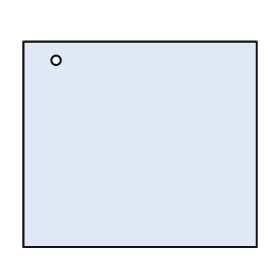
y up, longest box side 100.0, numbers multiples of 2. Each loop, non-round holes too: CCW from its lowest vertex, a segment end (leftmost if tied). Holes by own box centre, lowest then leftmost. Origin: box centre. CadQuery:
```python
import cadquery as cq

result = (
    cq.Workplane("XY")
    .moveTo(-50.0, -44.0)
    .lineTo(50.0, -44.0)
    .lineTo(50.0, 44.0)
    .lineTo(-50.0, 44.0)
    .close()
    .moveTo(-36.0, 36.0)
    .circle(2.0)
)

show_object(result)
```